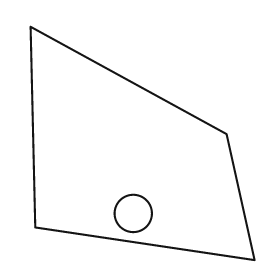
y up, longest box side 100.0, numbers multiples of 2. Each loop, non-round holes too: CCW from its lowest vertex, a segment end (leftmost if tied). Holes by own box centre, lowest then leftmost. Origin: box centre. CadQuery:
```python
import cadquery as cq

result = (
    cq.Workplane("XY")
    .moveTo(48.0, -50.0)
    .lineTo(36.0, 4.0)
    .lineTo(-48.0, 50.0)
    .lineTo(-46.0, -36.0)
    .close()
    .moveTo(-4.0, -30.0)
    .circle(8.0)
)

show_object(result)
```